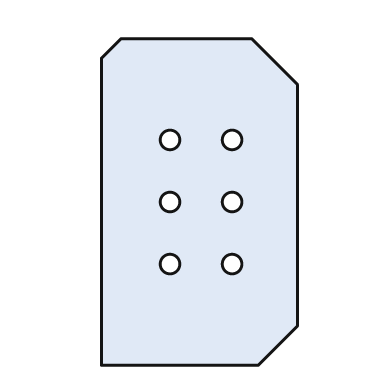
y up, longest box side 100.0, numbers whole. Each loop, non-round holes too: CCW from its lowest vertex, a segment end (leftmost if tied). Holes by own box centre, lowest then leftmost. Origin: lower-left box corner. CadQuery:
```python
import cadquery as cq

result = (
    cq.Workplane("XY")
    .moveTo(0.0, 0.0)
    .lineTo(48.0, 0.0)
    .lineTo(60.0, 12.0)
    .lineTo(60.0, 86.0)
    .lineTo(46.0, 100.0)
    .lineTo(6.0, 100.0)
    .lineTo(0.0, 94.0)
    .close()
    .moveTo(21.0, 31.0)
    .circle(3.0)
    .moveTo(40.0, 31.0)
    .circle(3.0)
    .moveTo(21.0, 50.0)
    .circle(3.0)
    .moveTo(40.0, 50.0)
    .circle(3.0)
    .moveTo(21.0, 69.0)
    .circle(3.0)
    .moveTo(40.0, 69.0)
    .circle(3.0)
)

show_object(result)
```